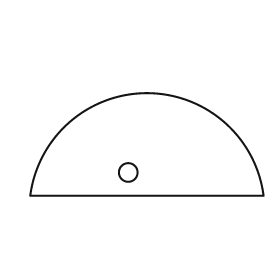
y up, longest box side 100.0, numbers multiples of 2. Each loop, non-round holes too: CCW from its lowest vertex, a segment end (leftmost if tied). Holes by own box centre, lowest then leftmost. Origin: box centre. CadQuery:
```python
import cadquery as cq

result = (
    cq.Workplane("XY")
    .moveTo(-50.0, -22.0)
    .lineTo(50.0, -22.0)
    .threePointArc((0.0, 22.0), (-50.0, -22.0))
    .close()
    .moveTo(-8.0, -12.0)
    .circle(4.0)
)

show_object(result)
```